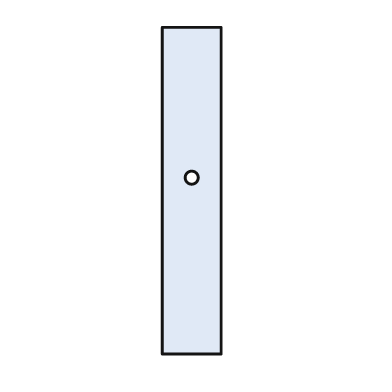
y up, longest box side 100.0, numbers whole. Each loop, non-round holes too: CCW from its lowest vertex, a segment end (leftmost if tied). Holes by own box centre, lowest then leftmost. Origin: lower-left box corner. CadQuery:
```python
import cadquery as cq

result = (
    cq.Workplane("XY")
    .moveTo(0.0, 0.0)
    .lineTo(18.0, 0.0)
    .lineTo(18.0, 100.0)
    .lineTo(0.0, 100.0)
    .close()
    .moveTo(9.0, 54.0)
    .circle(2.0)
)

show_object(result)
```